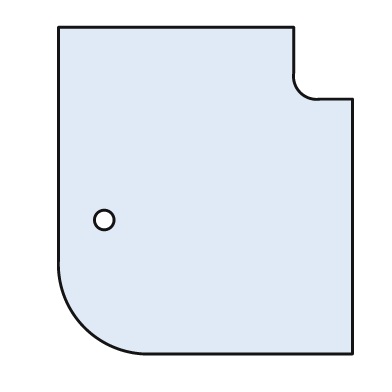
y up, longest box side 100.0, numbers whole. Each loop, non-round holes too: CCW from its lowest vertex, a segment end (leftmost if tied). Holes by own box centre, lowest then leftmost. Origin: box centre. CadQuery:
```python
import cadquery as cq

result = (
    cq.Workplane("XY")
    .moveTo(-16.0, -50.0)
    .lineTo(45.0, -50.0)
    .lineTo(45.0, 28.0)
    .lineTo(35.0, 28.0)
    .threePointArc((29.0, 30.0), (27.0, 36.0))
    .lineTo(27.0, 50.0)
    .lineTo(-45.0, 50.0)
    .lineTo(-45.0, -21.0)
    .threePointArc((-37.0, -42.0), (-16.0, -50.0))
    .close()
    .moveTo(-31.0, -9.0)
    .circle(3.0)
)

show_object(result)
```